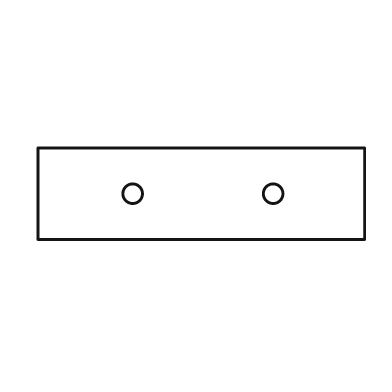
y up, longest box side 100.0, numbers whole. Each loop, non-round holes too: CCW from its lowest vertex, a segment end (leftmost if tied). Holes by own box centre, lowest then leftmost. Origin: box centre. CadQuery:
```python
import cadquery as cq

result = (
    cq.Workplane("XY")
    .moveTo(-50.0, -14.0)
    .lineTo(50.0, -14.0)
    .lineTo(50.0, 14.0)
    .lineTo(-50.0, 14.0)
    .close()
    .moveTo(-21.0, 0.0)
    .circle(3.0)
    .moveTo(22.0, 0.0)
    .circle(3.0)
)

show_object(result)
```